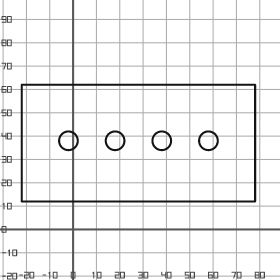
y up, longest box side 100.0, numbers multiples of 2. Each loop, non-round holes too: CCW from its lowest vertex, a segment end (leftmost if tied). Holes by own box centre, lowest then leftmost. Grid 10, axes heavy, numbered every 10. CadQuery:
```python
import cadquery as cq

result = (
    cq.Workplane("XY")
    .moveTo(-22.0, 12.0)
    .lineTo(78.0, 12.0)
    .lineTo(78.0, 62.0)
    .lineTo(-22.0, 62.0)
    .close()
    .moveTo(-2.0, 38.0)
    .circle(4.0)
    .moveTo(18.0, 38.0)
    .circle(4.0)
    .moveTo(38.0, 38.0)
    .circle(4.0)
    .moveTo(58.0, 38.0)
    .circle(4.0)
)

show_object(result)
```